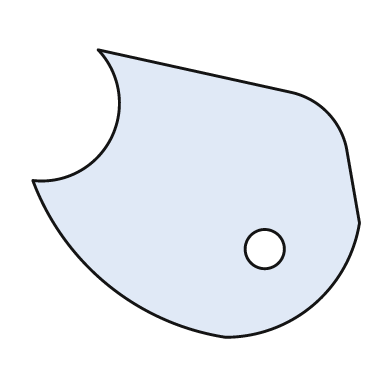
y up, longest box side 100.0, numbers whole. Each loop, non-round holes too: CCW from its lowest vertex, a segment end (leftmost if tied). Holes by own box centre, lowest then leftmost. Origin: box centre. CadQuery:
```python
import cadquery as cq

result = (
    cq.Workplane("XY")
    .moveTo(9.0, -44.0)
    .threePointArc((36.0, -34.0), (50.0, -9.0))
    .lineTo(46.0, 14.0)
    .threePointArc((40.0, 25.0), (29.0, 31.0))
    .lineTo(-30.0, 44.0)
    .threePointArc((-26.0, 17.0), (-50.0, 4.0))
    .threePointArc((-27.0, -28.0), (9.0, -44.0))
    .close()
    .moveTo(21.0, -17.0)
    .circle(6.0)
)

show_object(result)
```